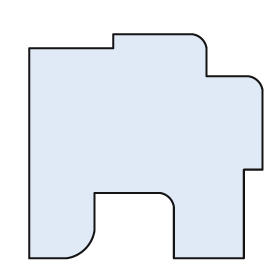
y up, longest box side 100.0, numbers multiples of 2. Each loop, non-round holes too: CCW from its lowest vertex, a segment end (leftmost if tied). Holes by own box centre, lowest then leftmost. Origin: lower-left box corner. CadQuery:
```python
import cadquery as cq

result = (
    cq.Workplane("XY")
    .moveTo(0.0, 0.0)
    .lineTo(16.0, 0.0)
    .threePointArc((24.0, 4.0), (28.0, 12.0))
    .lineTo(28.0, 28.0)
    .lineTo(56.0, 28.0)
    .threePointArc((60.0, 26.0), (62.0, 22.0))
    .lineTo(62.0, 0.0)
    .lineTo(92.0, 0.0)
    .lineTo(92.0, 38.0)
    .lineTo(100.0, 38.0)
    .lineTo(100.0, 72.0)
    .threePointArc((98.0, 76.0), (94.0, 78.0))
    .lineTo(76.0, 78.0)
    .lineTo(76.0, 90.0)
    .threePointArc((74.0, 94.0), (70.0, 96.0))
    .lineTo(36.0, 96.0)
    .lineTo(36.0, 90.0)
    .lineTo(0.0, 90.0)
    .close()
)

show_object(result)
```